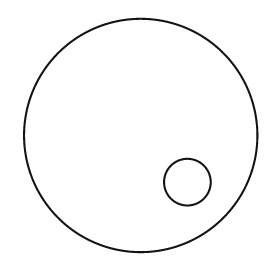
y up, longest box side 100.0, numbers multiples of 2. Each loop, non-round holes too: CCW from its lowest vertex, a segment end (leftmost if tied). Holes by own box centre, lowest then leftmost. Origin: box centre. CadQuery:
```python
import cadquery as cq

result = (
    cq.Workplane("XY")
    .moveTo(0.0, 0.0)
    .circle(50.0)
    .moveTo(20.0, -20.0)
    .circle(10.0)
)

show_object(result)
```